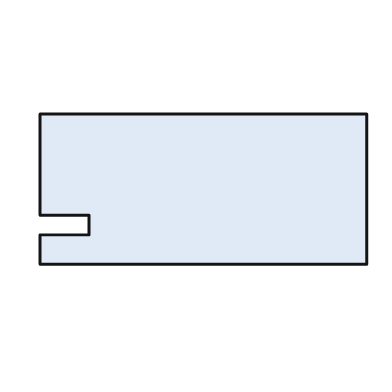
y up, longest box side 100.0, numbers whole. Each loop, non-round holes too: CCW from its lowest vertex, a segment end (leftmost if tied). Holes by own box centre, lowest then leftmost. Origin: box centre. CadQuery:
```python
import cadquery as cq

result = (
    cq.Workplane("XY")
    .moveTo(-50.0, -23.0)
    .lineTo(50.0, -23.0)
    .lineTo(50.0, 23.0)
    .lineTo(-50.0, 23.0)
    .lineTo(-50.0, -8.0)
    .lineTo(-35.0, -8.0)
    .lineTo(-35.0, -14.0)
    .lineTo(-50.0, -14.0)
    .close()
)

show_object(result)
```